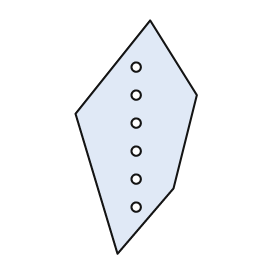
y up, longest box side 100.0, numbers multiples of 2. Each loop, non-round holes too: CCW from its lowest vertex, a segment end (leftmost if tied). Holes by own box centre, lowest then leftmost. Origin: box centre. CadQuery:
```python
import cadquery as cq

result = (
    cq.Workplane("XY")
    .moveTo(-8.0, -50.0)
    .lineTo(16.0, -22.0)
    .lineTo(26.0, 18.0)
    .lineTo(6.0, 50.0)
    .lineTo(-26.0, 10.0)
    .close()
    .moveTo(0.0, -30.0)
    .circle(2.0)
    .moveTo(0.0, -18.0)
    .circle(2.0)
    .moveTo(0.0, -6.0)
    .circle(2.0)
    .moveTo(0.0, 6.0)
    .circle(2.0)
    .moveTo(0.0, 18.0)
    .circle(2.0)
    .moveTo(0.0, 30.0)
    .circle(2.0)
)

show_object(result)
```